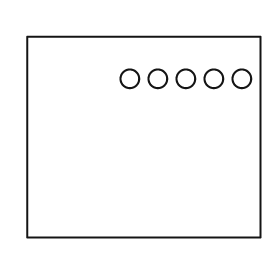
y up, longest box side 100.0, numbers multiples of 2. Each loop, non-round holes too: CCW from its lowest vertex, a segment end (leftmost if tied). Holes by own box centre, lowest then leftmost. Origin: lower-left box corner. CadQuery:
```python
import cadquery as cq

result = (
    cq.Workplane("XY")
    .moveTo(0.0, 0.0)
    .lineTo(100.0, 0.0)
    .lineTo(100.0, 86.0)
    .lineTo(0.0, 86.0)
    .close()
    .moveTo(44.0, 68.0)
    .circle(4.0)
    .moveTo(56.0, 68.0)
    .circle(4.0)
    .moveTo(68.0, 68.0)
    .circle(4.0)
    .moveTo(80.0, 68.0)
    .circle(4.0)
    .moveTo(92.0, 68.0)
    .circle(4.0)
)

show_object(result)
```